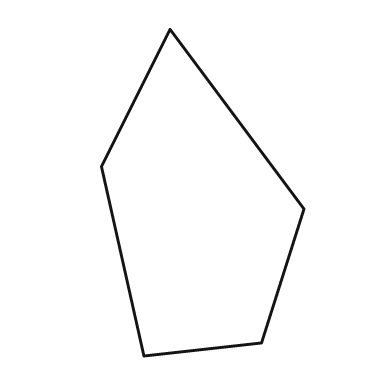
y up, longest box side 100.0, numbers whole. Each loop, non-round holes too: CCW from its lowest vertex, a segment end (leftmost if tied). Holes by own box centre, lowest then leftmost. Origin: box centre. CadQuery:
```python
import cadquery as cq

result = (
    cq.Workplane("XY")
    .moveTo(-18.0, -50.0)
    .lineTo(18.0, -46.0)
    .lineTo(31.0, -5.0)
    .lineTo(-10.0, 50.0)
    .lineTo(-31.0, 8.0)
    .close()
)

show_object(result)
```